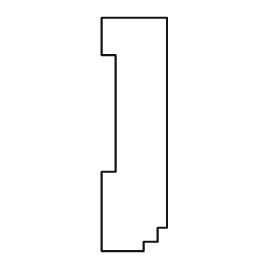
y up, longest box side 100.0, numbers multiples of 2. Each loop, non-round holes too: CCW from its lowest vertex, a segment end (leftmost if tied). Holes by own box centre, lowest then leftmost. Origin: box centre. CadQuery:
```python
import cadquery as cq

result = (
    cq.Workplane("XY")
    .moveTo(-14.0, -50.0)
    .lineTo(4.0, -50.0)
    .lineTo(4.0, -46.0)
    .lineTo(10.0, -46.0)
    .lineTo(10.0, -40.0)
    .lineTo(14.0, -40.0)
    .lineTo(14.0, 50.0)
    .lineTo(-14.0, 50.0)
    .lineTo(-14.0, 34.0)
    .lineTo(-8.0, 34.0)
    .lineTo(-8.0, -16.0)
    .lineTo(-14.0, -16.0)
    .close()
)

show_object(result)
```